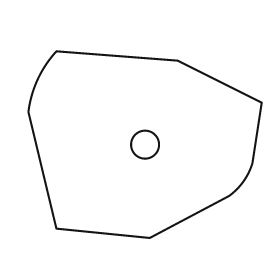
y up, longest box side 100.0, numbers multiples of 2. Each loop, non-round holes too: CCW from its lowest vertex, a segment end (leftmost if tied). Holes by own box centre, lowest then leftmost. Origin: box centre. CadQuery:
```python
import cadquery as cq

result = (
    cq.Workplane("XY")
    .moveTo(2.0, -40.0)
    .lineTo(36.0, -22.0)
    .threePointArc((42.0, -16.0), (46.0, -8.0))
    .lineTo(50.0, 18.0)
    .lineTo(14.0, 36.0)
    .lineTo(-38.0, 40.0)
    .threePointArc((-46.0, 28.0), (-50.0, 14.0))
    .lineTo(-38.0, -36.0)
    .close()
    .moveTo(0.0, 0.0)
    .circle(6.0)
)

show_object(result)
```